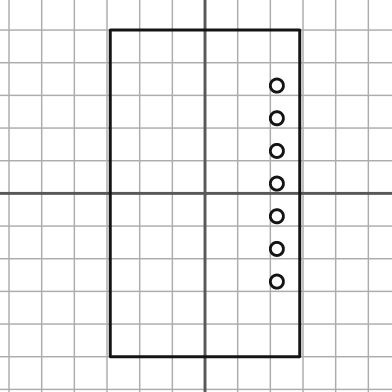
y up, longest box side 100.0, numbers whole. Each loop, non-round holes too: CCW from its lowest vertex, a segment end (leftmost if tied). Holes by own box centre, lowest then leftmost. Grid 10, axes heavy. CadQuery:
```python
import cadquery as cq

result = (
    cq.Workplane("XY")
    .moveTo(-29.0, -50.0)
    .lineTo(29.0, -50.0)
    .lineTo(29.0, 50.0)
    .lineTo(-29.0, 50.0)
    .close()
    .moveTo(22.0, -27.0)
    .circle(2.0)
    .moveTo(22.0, -17.0)
    .circle(2.0)
    .moveTo(22.0, -7.0)
    .circle(2.0)
    .moveTo(22.0, 3.0)
    .circle(2.0)
    .moveTo(22.0, 13.0)
    .circle(2.0)
    .moveTo(22.0, 23.0)
    .circle(2.0)
    .moveTo(22.0, 33.0)
    .circle(2.0)
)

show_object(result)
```